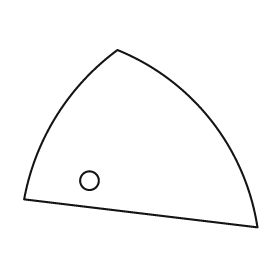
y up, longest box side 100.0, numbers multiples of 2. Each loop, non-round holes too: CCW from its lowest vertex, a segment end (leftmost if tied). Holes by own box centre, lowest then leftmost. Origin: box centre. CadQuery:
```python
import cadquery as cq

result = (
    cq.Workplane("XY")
    .moveTo(50.0, -38.0)
    .threePointArc((30.0, 8.0), (-10.0, 38.0))
    .threePointArc((-36.0, 10.0), (-50.0, -26.0))
    .close()
    .moveTo(-22.0, -18.0)
    .circle(4.0)
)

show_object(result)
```